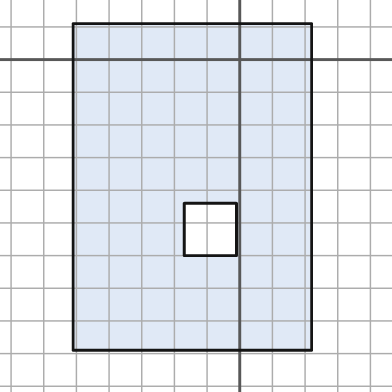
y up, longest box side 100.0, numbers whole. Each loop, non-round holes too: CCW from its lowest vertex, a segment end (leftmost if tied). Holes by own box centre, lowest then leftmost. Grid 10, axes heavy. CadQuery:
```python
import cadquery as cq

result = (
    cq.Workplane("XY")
    .moveTo(-51.0, -89.0)
    .lineTo(22.0, -89.0)
    .lineTo(22.0, 11.0)
    .lineTo(-51.0, 11.0)
    .close()
    .moveTo(-17.0, -60.0)
    .lineTo(-1.0, -60.0)
    .lineTo(-1.0, -44.0)
    .lineTo(-17.0, -44.0)
    .close()
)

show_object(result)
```